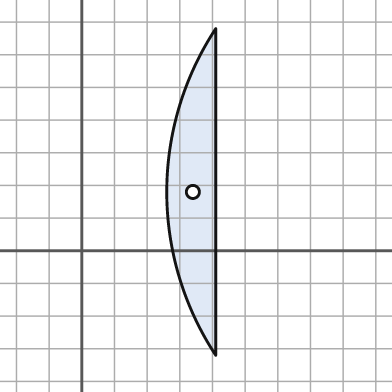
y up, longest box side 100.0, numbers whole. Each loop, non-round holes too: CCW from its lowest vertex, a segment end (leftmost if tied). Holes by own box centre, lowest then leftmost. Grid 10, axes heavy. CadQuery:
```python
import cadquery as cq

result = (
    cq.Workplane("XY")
    .moveTo(41.0, -32.0)
    .lineTo(41.0, 68.0)
    .threePointArc((26.0, 18.0), (41.0, -32.0))
    .close()
    .moveTo(34.0, 18.0)
    .circle(2.0)
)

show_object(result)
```